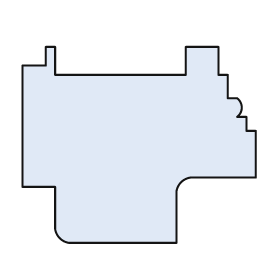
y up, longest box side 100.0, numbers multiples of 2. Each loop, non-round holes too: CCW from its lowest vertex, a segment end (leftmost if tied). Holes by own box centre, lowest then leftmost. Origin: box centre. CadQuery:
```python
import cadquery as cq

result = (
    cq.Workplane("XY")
    .moveTo(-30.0, -42.0)
    .lineTo(16.0, -42.0)
    .lineTo(16.0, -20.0)
    .threePointArc((18.0, -16.0), (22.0, -14.0))
    .lineTo(50.0, -14.0)
    .lineTo(50.0, 6.0)
    .lineTo(46.0, 6.0)
    .lineTo(46.0, 12.0)
    .lineTo(42.0, 12.0)
    .threePointArc((44.0, 16.0), (42.0, 20.0))
    .lineTo(38.0, 20.0)
    .lineTo(38.0, 30.0)
    .lineTo(34.0, 30.0)
    .lineTo(34.0, 42.0)
    .lineTo(20.0, 42.0)
    .lineTo(20.0, 30.0)
    .lineTo(-36.0, 30.0)
    .lineTo(-36.0, 42.0)
    .lineTo(-40.0, 42.0)
    .lineTo(-40.0, 34.0)
    .lineTo(-50.0, 34.0)
    .lineTo(-50.0, -18.0)
    .lineTo(-36.0, -18.0)
    .lineTo(-36.0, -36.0)
    .threePointArc((-34.0, -40.0), (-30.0, -42.0))
    .close()
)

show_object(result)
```